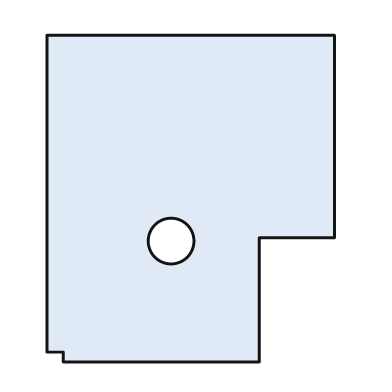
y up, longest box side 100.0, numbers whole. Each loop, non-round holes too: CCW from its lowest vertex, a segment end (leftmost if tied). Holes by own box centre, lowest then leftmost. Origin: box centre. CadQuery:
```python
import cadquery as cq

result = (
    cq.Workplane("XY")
    .moveTo(-39.0, -50.0)
    .lineTo(21.0, -50.0)
    .lineTo(21.0, -12.0)
    .lineTo(44.0, -12.0)
    .lineTo(44.0, 50.0)
    .lineTo(-44.0, 50.0)
    .lineTo(-44.0, -47.0)
    .lineTo(-39.0, -47.0)
    .close()
    .moveTo(-6.0, -13.0)
    .circle(7.0)
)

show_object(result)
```